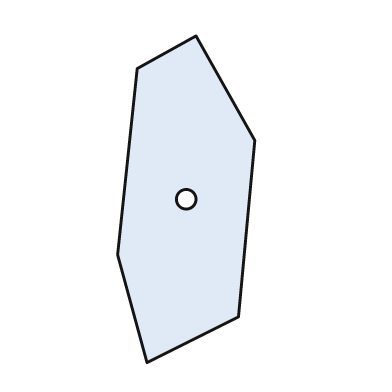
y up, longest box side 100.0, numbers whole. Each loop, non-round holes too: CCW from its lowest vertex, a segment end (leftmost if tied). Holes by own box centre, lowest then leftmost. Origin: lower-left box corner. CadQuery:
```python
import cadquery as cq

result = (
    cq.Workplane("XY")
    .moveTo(9.0, 0.0)
    .lineTo(37.0, 14.0)
    .lineTo(42.0, 68.0)
    .lineTo(24.0, 100.0)
    .lineTo(6.0, 90.0)
    .lineTo(0.0, 33.0)
    .close()
    .moveTo(21.0, 50.0)
    .circle(3.0)
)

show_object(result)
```